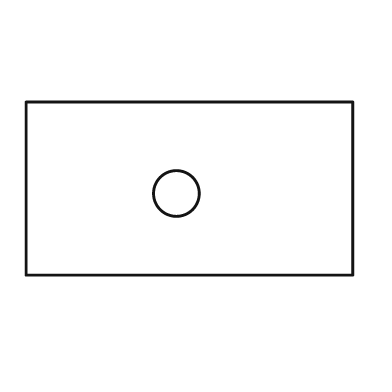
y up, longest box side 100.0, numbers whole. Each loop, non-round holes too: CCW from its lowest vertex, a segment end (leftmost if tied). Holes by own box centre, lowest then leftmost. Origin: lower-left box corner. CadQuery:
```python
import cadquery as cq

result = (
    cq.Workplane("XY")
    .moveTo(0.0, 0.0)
    .lineTo(100.0, 0.0)
    .lineTo(100.0, 53.0)
    .lineTo(0.0, 53.0)
    .close()
    .moveTo(46.0, 25.0)
    .circle(7.0)
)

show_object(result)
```